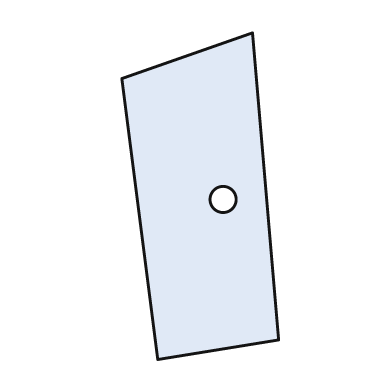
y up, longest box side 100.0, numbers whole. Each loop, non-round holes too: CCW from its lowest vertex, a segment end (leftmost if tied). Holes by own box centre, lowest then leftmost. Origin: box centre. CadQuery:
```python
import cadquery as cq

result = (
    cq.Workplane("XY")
    .moveTo(-13.0, -50.0)
    .lineTo(24.0, -44.0)
    .lineTo(16.0, 50.0)
    .lineTo(-24.0, 36.0)
    .close()
    .moveTo(7.0, -1.0)
    .circle(4.0)
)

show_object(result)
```